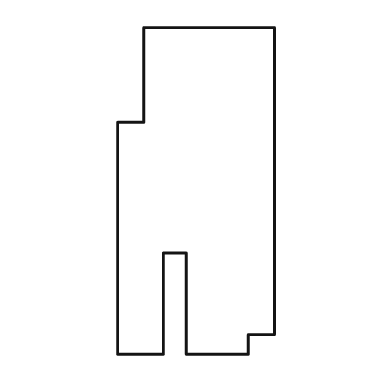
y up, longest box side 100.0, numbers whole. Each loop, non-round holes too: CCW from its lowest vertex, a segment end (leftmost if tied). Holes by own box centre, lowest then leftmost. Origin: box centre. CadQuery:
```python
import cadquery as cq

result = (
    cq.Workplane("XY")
    .moveTo(-24.0, -50.0)
    .lineTo(-10.0, -50.0)
    .lineTo(-10.0, -19.0)
    .lineTo(-3.0, -19.0)
    .lineTo(-3.0, -50.0)
    .lineTo(16.0, -50.0)
    .lineTo(16.0, -44.0)
    .lineTo(24.0, -44.0)
    .lineTo(24.0, 50.0)
    .lineTo(-16.0, 50.0)
    .lineTo(-16.0, 21.0)
    .lineTo(-24.0, 21.0)
    .close()
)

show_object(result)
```